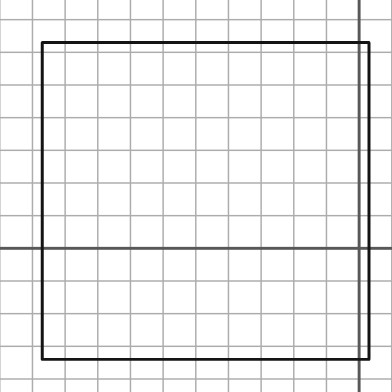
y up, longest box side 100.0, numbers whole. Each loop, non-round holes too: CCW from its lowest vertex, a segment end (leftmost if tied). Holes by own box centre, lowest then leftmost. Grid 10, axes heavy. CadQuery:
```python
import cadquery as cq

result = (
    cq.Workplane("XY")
    .moveTo(-97.0, -34.0)
    .lineTo(3.0, -34.0)
    .lineTo(3.0, 63.0)
    .lineTo(-97.0, 63.0)
    .close()
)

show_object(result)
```